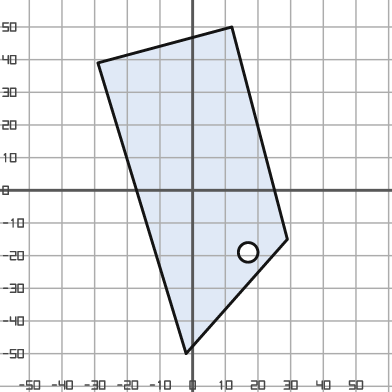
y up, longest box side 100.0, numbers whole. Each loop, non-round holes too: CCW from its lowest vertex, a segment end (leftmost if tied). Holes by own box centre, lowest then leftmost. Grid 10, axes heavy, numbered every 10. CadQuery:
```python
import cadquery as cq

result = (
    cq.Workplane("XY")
    .moveTo(-2.0, -50.0)
    .lineTo(29.0, -15.0)
    .lineTo(12.0, 50.0)
    .lineTo(-29.0, 39.0)
    .close()
    .moveTo(17.0, -19.0)
    .circle(3.0)
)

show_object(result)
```